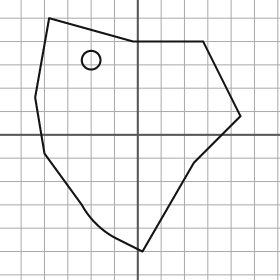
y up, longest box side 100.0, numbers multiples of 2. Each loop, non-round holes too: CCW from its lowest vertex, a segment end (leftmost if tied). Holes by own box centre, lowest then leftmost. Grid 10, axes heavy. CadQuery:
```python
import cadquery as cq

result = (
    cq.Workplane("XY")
    .moveTo(2.0, -50.0)
    .lineTo(24.0, -12.0)
    .lineTo(44.0, 8.0)
    .lineTo(28.0, 40.0)
    .lineTo(-2.0, 40.0)
    .lineTo(-38.0, 50.0)
    .lineTo(-44.0, 16.0)
    .lineTo(-40.0, -8.0)
    .lineTo(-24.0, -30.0)
    .threePointArc((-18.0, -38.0), (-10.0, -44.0))
    .close()
    .moveTo(-20.0, 32.0)
    .circle(4.0)
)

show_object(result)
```